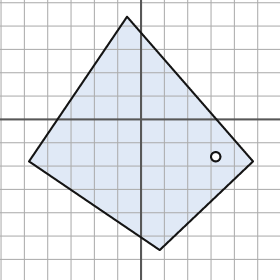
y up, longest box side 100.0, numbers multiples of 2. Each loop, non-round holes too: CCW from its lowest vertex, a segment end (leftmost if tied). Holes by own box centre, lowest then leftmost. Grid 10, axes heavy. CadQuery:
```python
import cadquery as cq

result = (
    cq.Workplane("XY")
    .moveTo(8.0, -56.0)
    .lineTo(48.0, -18.0)
    .lineTo(-6.0, 44.0)
    .lineTo(-48.0, -18.0)
    .close()
    .moveTo(32.0, -16.0)
    .circle(2.0)
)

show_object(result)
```